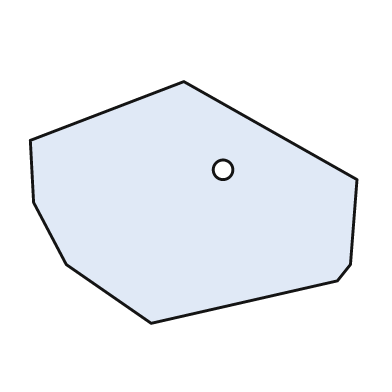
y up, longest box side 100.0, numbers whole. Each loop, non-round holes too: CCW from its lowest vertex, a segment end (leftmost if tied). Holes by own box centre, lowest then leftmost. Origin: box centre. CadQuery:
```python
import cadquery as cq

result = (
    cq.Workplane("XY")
    .moveTo(-13.0, -37.0)
    .lineTo(44.0, -24.0)
    .lineTo(48.0, -19.0)
    .lineTo(50.0, 7.0)
    .lineTo(-3.0, 37.0)
    .lineTo(-50.0, 19.0)
    .lineTo(-49.0, 0.0)
    .lineTo(-39.0, -19.0)
    .close()
    .moveTo(9.0, 10.0)
    .circle(3.0)
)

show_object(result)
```